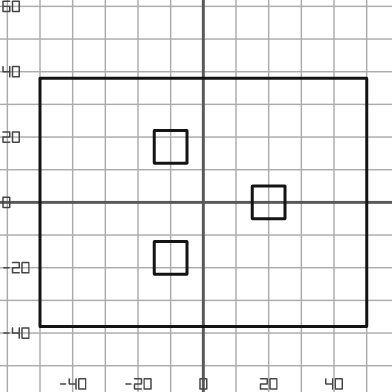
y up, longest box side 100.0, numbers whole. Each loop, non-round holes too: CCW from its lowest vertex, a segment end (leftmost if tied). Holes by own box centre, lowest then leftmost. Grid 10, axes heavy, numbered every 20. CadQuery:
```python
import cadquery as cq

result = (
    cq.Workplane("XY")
    .moveTo(-50.0, -38.0)
    .lineTo(50.0, -38.0)
    .lineTo(50.0, 38.0)
    .lineTo(-50.0, 38.0)
    .close()
    .moveTo(-15.0, -22.0)
    .lineTo(-5.0, -22.0)
    .lineTo(-5.0, -12.0)
    .lineTo(-15.0, -12.0)
    .close()
    .moveTo(15.0, -5.0)
    .lineTo(25.0, -5.0)
    .lineTo(25.0, 5.0)
    .lineTo(15.0, 5.0)
    .close()
    .moveTo(-15.0, 12.0)
    .lineTo(-5.0, 12.0)
    .lineTo(-5.0, 22.0)
    .lineTo(-15.0, 22.0)
    .close()
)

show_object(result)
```